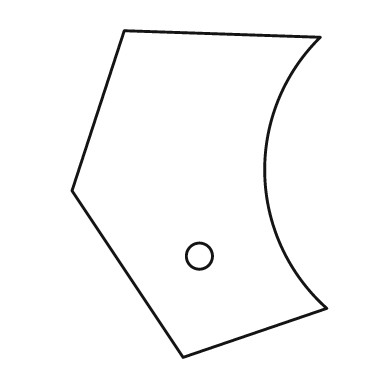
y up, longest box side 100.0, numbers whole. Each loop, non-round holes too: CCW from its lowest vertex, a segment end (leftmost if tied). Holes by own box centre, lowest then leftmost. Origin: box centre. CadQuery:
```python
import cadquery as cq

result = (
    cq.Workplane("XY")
    .moveTo(-5.0, -50.0)
    .lineTo(39.0, -35.0)
    .threePointArc((20.0, 6.0), (37.0, 48.0))
    .lineTo(-23.0, 50.0)
    .lineTo(-39.0, 1.0)
    .close()
    .moveTo(0.0, -19.0)
    .circle(4.0)
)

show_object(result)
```